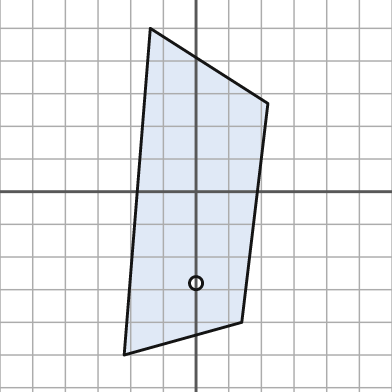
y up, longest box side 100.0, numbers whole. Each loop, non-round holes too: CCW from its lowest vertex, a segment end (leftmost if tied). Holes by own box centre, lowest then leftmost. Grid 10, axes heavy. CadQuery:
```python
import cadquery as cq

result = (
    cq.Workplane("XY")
    .moveTo(-22.0, -50.0)
    .lineTo(14.0, -40.0)
    .lineTo(22.0, 27.0)
    .lineTo(-14.0, 50.0)
    .close()
    .moveTo(0.0, -28.0)
    .circle(2.0)
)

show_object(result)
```